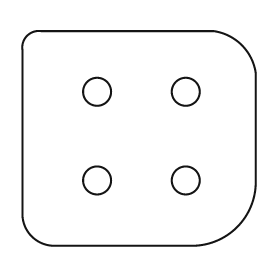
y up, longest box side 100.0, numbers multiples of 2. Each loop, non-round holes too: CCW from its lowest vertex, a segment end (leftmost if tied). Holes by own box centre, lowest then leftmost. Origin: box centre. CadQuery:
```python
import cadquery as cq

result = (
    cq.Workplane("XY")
    .moveTo(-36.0, -46.0)
    .lineTo(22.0, -46.0)
    .threePointArc((42.0, -38.0), (50.0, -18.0))
    .lineTo(50.0, 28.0)
    .threePointArc((44.0, 40.0), (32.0, 46.0))
    .lineTo(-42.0, 46.0)
    .threePointArc((-48.0, 44.0), (-50.0, 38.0))
    .lineTo(-50.0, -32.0)
    .threePointArc((-46.0, -42.0), (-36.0, -46.0))
    .close()
    .moveTo(-18.0, -18.0)
    .circle(6.0)
    .moveTo(20.0, -18.0)
    .circle(6.0)
    .moveTo(-18.0, 20.0)
    .circle(6.0)
    .moveTo(20.0, 20.0)
    .circle(6.0)
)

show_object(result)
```